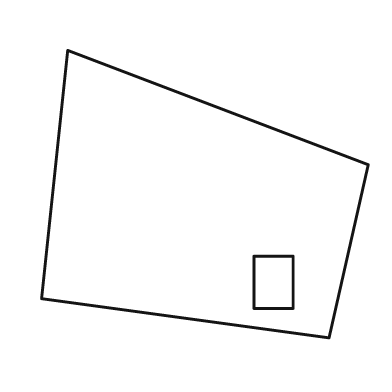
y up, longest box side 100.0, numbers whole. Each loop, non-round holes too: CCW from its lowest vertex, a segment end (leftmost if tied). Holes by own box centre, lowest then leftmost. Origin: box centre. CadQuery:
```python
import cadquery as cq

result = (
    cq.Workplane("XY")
    .moveTo(38.0, -44.0)
    .lineTo(50.0, 9.0)
    .lineTo(-42.0, 44.0)
    .lineTo(-50.0, -32.0)
    .close()
    .moveTo(15.0, -35.0)
    .lineTo(27.0, -35.0)
    .lineTo(27.0, -19.0)
    .lineTo(15.0, -19.0)
    .close()
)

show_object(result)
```